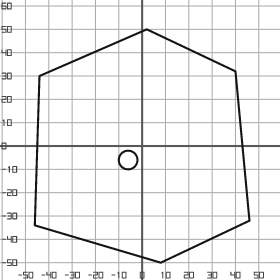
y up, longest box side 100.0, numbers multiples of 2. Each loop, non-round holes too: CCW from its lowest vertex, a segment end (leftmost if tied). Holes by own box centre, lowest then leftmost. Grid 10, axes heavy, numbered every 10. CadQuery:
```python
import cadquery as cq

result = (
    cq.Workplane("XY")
    .moveTo(8.0, -50.0)
    .lineTo(46.0, -32.0)
    .lineTo(40.0, 32.0)
    .lineTo(2.0, 50.0)
    .lineTo(-44.0, 30.0)
    .lineTo(-46.0, -34.0)
    .close()
    .moveTo(-6.0, -6.0)
    .circle(4.0)
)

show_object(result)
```